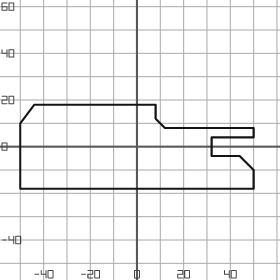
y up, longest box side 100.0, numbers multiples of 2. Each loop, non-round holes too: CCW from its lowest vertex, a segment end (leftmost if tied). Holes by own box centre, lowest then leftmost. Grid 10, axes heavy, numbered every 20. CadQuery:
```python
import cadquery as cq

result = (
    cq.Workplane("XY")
    .moveTo(-50.0, -18.0)
    .lineTo(50.0, -18.0)
    .lineTo(50.0, -10.0)
    .lineTo(44.0, -4.0)
    .lineTo(32.0, -4.0)
    .lineTo(32.0, 4.0)
    .lineTo(50.0, 4.0)
    .lineTo(50.0, 8.0)
    .lineTo(12.0, 8.0)
    .lineTo(8.0, 12.0)
    .lineTo(8.0, 18.0)
    .lineTo(-44.0, 18.0)
    .lineTo(-50.0, 10.0)
    .close()
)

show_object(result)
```